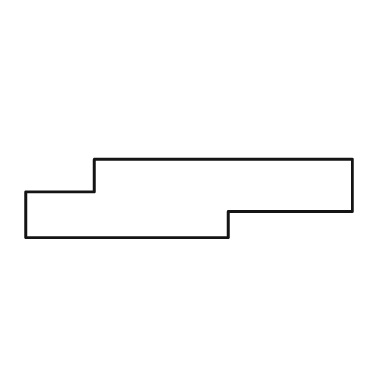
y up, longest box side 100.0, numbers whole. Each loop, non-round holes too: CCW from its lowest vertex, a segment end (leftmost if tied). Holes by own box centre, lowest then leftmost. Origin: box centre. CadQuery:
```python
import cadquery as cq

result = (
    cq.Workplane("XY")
    .moveTo(-50.0, -12.0)
    .lineTo(12.0, -12.0)
    .lineTo(12.0, -4.0)
    .lineTo(50.0, -4.0)
    .lineTo(50.0, 12.0)
    .lineTo(-29.0, 12.0)
    .lineTo(-29.0, 2.0)
    .lineTo(-50.0, 2.0)
    .close()
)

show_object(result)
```